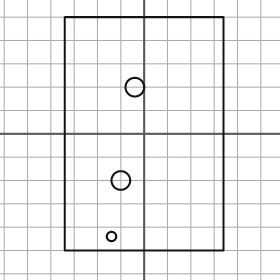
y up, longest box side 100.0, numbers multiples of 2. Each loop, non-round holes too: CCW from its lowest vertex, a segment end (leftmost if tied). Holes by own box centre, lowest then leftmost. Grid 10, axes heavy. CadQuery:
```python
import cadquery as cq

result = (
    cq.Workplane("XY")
    .moveTo(-34.0, -50.0)
    .lineTo(34.0, -50.0)
    .lineTo(34.0, 50.0)
    .lineTo(-34.0, 50.0)
    .close()
    .moveTo(-14.0, -44.0)
    .circle(2.0)
    .moveTo(-10.0, -20.0)
    .circle(4.0)
    .moveTo(-4.0, 20.0)
    .circle(4.0)
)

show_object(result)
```